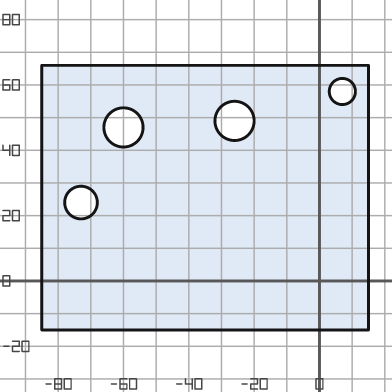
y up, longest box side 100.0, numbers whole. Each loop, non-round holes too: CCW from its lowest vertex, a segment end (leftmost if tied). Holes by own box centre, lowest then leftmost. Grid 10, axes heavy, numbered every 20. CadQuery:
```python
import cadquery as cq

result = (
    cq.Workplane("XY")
    .moveTo(-85.0, -15.0)
    .lineTo(15.0, -15.0)
    .lineTo(15.0, 66.0)
    .lineTo(-85.0, 66.0)
    .close()
    .moveTo(-73.0, 24.0)
    .circle(5.0)
    .moveTo(-60.0, 47.0)
    .circle(6.0)
    .moveTo(-26.0, 49.0)
    .circle(6.0)
    .moveTo(7.0, 58.0)
    .circle(4.0)
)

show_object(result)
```